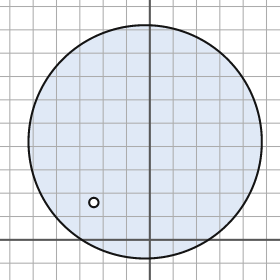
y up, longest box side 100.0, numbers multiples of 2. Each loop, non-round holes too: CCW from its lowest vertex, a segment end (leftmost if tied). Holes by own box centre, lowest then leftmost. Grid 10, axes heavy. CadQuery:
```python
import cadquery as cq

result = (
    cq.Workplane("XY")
    .moveTo(-2.0, 42.0)
    .circle(50.0)
    .moveTo(-24.0, 16.0)
    .circle(2.0)
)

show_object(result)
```